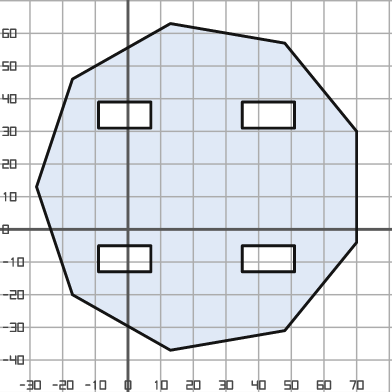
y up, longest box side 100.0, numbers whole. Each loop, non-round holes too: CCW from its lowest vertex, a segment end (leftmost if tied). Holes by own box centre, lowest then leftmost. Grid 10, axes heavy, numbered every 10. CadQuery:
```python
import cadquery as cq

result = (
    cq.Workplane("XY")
    .moveTo(13.0, -37.0)
    .lineTo(48.0, -31.0)
    .lineTo(70.0, -4.0)
    .lineTo(70.0, 30.0)
    .lineTo(48.0, 57.0)
    .lineTo(13.0, 63.0)
    .lineTo(-17.0, 46.0)
    .lineTo(-28.0, 13.0)
    .lineTo(-17.0, -20.0)
    .close()
    .moveTo(-9.0, -13.0)
    .lineTo(7.0, -13.0)
    .lineTo(7.0, -5.0)
    .lineTo(-9.0, -5.0)
    .close()
    .moveTo(35.0, -13.0)
    .lineTo(51.0, -13.0)
    .lineTo(51.0, -5.0)
    .lineTo(35.0, -5.0)
    .close()
    .moveTo(-9.0, 31.0)
    .lineTo(7.0, 31.0)
    .lineTo(7.0, 39.0)
    .lineTo(-9.0, 39.0)
    .close()
    .moveTo(35.0, 31.0)
    .lineTo(51.0, 31.0)
    .lineTo(51.0, 39.0)
    .lineTo(35.0, 39.0)
    .close()
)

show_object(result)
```